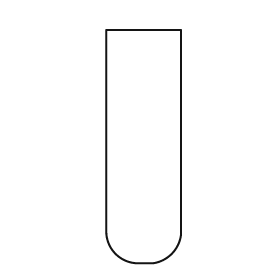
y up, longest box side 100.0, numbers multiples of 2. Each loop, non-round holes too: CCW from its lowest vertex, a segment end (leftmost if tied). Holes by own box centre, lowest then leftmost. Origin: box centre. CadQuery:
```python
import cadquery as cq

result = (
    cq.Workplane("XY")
    .moveTo(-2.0, -50.0)
    .lineTo(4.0, -50.0)
    .threePointArc((12.0, -46.0), (16.0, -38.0))
    .lineTo(16.0, 50.0)
    .lineTo(-16.0, 50.0)
    .lineTo(-16.0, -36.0)
    .threePointArc((-12.0, -46.0), (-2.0, -50.0))
    .close()
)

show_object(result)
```